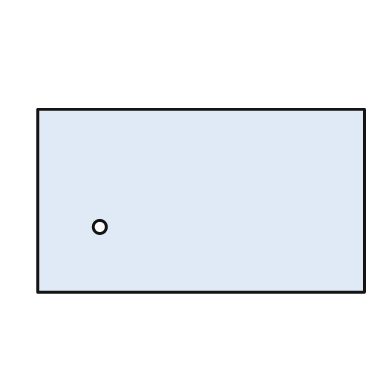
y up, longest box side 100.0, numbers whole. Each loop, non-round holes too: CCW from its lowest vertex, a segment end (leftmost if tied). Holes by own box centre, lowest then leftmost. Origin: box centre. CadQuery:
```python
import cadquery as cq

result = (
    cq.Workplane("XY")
    .moveTo(-50.0, -28.0)
    .lineTo(50.0, -28.0)
    .lineTo(50.0, 28.0)
    .lineTo(-50.0, 28.0)
    .close()
    .moveTo(-31.0, -8.0)
    .circle(2.0)
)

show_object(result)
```